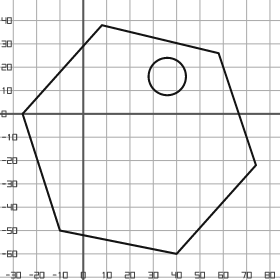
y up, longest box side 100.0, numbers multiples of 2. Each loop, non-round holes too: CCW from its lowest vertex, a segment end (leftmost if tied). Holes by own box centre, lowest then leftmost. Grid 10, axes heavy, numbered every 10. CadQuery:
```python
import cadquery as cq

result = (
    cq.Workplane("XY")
    .moveTo(40.0, -60.0)
    .lineTo(74.0, -22.0)
    .lineTo(58.0, 26.0)
    .lineTo(8.0, 38.0)
    .lineTo(-26.0, 0.0)
    .lineTo(-10.0, -50.0)
    .close()
    .moveTo(36.0, 16.0)
    .circle(8.0)
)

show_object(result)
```